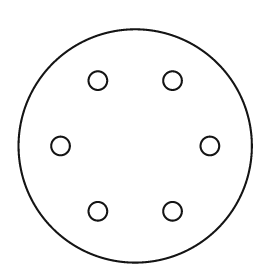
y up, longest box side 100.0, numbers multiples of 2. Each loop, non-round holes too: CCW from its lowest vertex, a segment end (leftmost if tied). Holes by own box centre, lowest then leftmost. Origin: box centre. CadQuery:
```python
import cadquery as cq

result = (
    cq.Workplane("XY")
    .moveTo(0.0, 0.0)
    .circle(50.0)
    .moveTo(-16.0, -28.0)
    .circle(4.0)
    .moveTo(16.0, -28.0)
    .circle(4.0)
    .moveTo(-32.0, 0.0)
    .circle(4.0)
    .moveTo(32.0, 0.0)
    .circle(4.0)
    .moveTo(-16.0, 28.0)
    .circle(4.0)
    .moveTo(16.0, 28.0)
    .circle(4.0)
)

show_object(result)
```